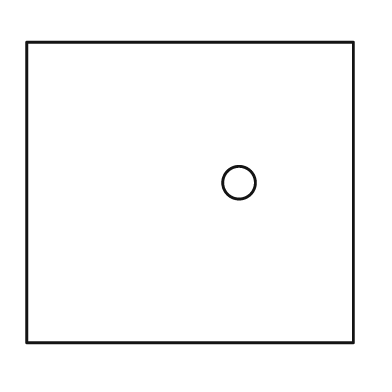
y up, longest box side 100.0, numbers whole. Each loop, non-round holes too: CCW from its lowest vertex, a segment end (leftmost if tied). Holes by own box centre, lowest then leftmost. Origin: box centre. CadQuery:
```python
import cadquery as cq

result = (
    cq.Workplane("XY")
    .moveTo(-50.0, -46.0)
    .lineTo(50.0, -46.0)
    .lineTo(50.0, 46.0)
    .lineTo(-50.0, 46.0)
    .close()
    .moveTo(15.0, 3.0)
    .circle(5.0)
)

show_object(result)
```